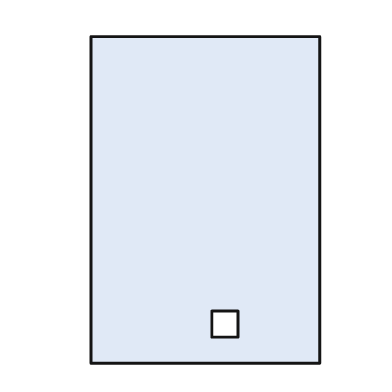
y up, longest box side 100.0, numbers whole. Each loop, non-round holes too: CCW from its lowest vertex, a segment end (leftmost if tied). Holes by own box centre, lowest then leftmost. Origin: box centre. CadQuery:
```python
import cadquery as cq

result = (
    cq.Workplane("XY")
    .moveTo(-35.0, -50.0)
    .lineTo(35.0, -50.0)
    .lineTo(35.0, 50.0)
    .lineTo(-35.0, 50.0)
    .close()
    .moveTo(2.0, -42.0)
    .lineTo(10.0, -42.0)
    .lineTo(10.0, -34.0)
    .lineTo(2.0, -34.0)
    .close()
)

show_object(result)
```